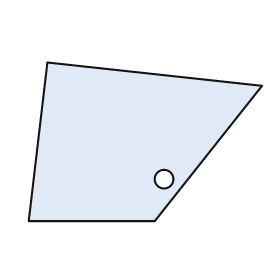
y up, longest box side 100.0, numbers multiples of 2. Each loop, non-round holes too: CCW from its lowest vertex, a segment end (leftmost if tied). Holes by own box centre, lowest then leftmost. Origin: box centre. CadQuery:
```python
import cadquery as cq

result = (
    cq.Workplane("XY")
    .moveTo(-50.0, -34.0)
    .lineTo(4.0, -34.0)
    .lineTo(50.0, 24.0)
    .lineTo(-42.0, 34.0)
    .close()
    .moveTo(8.0, -16.0)
    .circle(4.0)
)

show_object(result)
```